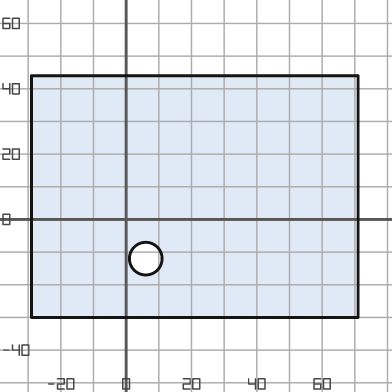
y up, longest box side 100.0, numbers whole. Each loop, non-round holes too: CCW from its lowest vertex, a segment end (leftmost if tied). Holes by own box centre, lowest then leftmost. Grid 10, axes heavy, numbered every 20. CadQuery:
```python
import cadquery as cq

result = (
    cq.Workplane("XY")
    .moveTo(-29.0, -30.0)
    .lineTo(71.0, -30.0)
    .lineTo(71.0, 44.0)
    .lineTo(-29.0, 44.0)
    .close()
    .moveTo(6.0, -12.0)
    .circle(5.0)
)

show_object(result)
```